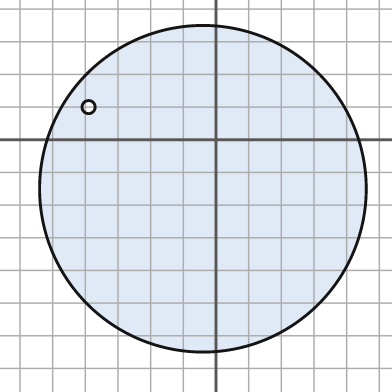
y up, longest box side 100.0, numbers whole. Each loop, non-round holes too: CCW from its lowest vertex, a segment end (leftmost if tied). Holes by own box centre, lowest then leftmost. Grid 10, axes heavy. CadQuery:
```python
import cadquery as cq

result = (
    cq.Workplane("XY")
    .moveTo(-4.0, -15.0)
    .circle(50.0)
    .moveTo(-39.0, 10.0)
    .circle(2.0)
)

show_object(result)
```